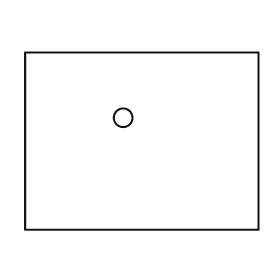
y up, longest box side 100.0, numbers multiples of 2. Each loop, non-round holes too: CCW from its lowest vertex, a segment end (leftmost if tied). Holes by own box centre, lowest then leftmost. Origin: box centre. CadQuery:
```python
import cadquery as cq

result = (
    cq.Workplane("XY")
    .moveTo(-50.0, -38.0)
    .lineTo(50.0, -38.0)
    .lineTo(50.0, 38.0)
    .lineTo(-50.0, 38.0)
    .close()
    .moveTo(-8.0, 10.0)
    .circle(4.0)
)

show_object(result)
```